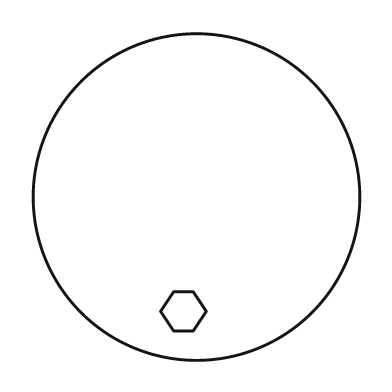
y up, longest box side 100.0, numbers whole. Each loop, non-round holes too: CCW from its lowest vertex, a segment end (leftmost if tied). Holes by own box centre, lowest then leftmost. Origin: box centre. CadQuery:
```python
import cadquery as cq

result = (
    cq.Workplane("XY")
    .moveTo(0.0, 0.0)
    .circle(50.0)
    .moveTo(-7.0, -41.0)
    .lineTo(-1.0, -41.0)
    .lineTo(3.0, -35.0)
    .lineTo(-1.0, -29.0)
    .lineTo(-7.0, -29.0)
    .lineTo(-11.0, -35.0)
    .close()
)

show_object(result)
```